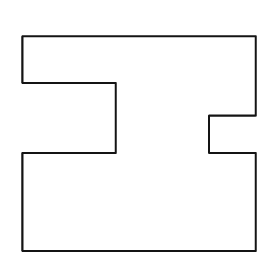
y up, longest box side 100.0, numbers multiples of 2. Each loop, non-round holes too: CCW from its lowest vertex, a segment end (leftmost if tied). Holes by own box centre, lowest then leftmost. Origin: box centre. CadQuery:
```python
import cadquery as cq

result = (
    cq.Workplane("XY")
    .moveTo(-50.0, -46.0)
    .lineTo(50.0, -46.0)
    .lineTo(50.0, -4.0)
    .lineTo(30.0, -4.0)
    .lineTo(30.0, 12.0)
    .lineTo(50.0, 12.0)
    .lineTo(50.0, 46.0)
    .lineTo(-50.0, 46.0)
    .lineTo(-50.0, 26.0)
    .lineTo(-10.0, 26.0)
    .lineTo(-10.0, -4.0)
    .lineTo(-50.0, -4.0)
    .close()
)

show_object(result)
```